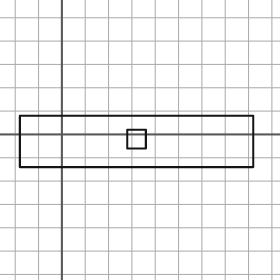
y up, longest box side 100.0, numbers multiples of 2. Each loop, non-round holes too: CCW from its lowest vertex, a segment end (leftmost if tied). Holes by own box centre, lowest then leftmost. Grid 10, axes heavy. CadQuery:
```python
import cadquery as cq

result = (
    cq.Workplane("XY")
    .moveTo(-18.0, -14.0)
    .lineTo(82.0, -14.0)
    .lineTo(82.0, 8.0)
    .lineTo(-18.0, 8.0)
    .close()
    .moveTo(28.0, -6.0)
    .lineTo(36.0, -6.0)
    .lineTo(36.0, 2.0)
    .lineTo(28.0, 2.0)
    .close()
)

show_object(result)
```